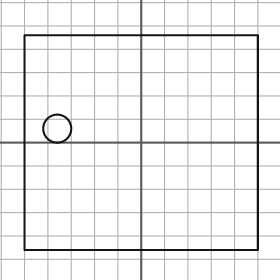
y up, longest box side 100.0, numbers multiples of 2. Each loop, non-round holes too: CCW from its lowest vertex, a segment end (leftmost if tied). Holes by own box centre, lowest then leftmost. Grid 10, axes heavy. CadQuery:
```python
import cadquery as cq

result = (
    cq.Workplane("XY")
    .moveTo(-50.0, -46.0)
    .lineTo(50.0, -46.0)
    .lineTo(50.0, 46.0)
    .lineTo(-50.0, 46.0)
    .close()
    .moveTo(-36.0, 6.0)
    .circle(6.0)
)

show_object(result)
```